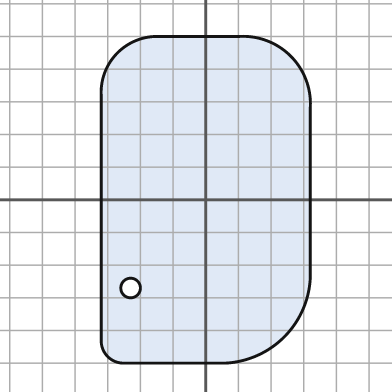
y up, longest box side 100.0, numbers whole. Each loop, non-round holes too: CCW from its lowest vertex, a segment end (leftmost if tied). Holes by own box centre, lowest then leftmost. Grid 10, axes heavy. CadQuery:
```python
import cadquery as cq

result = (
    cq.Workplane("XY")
    .moveTo(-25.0, -50.0)
    .lineTo(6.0, -50.0)
    .threePointArc((24.0, -42.0), (32.0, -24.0))
    .lineTo(32.0, 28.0)
    .threePointArc((26.0, 44.0), (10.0, 50.0))
    .lineTo(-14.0, 50.0)
    .threePointArc((-27.0, 45.0), (-32.0, 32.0))
    .lineTo(-32.0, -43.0)
    .threePointArc((-30.0, -48.0), (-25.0, -50.0))
    .close()
    .moveTo(-23.0, -27.0)
    .circle(3.0)
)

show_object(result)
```